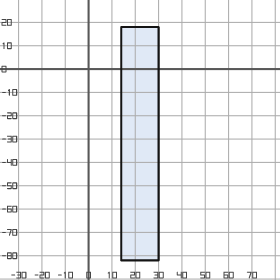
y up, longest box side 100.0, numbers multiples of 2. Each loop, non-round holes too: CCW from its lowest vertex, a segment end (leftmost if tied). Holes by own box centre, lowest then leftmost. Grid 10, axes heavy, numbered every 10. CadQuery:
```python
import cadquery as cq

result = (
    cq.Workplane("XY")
    .moveTo(14.0, -82.0)
    .lineTo(30.0, -82.0)
    .lineTo(30.0, 18.0)
    .lineTo(14.0, 18.0)
    .close()
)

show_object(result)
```